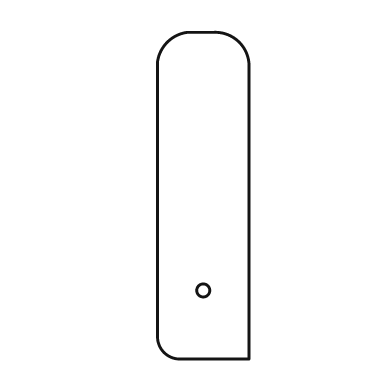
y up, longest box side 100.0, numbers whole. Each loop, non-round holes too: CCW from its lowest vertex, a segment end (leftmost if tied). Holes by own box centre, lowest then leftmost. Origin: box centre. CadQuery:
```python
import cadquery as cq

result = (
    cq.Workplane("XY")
    .moveTo(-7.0, -50.0)
    .lineTo(14.0, -50.0)
    .lineTo(14.0, 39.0)
    .threePointArc((11.0, 47.0), (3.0, 50.0))
    .lineTo(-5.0, 50.0)
    .threePointArc((-11.0, 47.0), (-14.0, 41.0))
    .lineTo(-14.0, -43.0)
    .threePointArc((-12.0, -48.0), (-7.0, -50.0))
    .close()
    .moveTo(0.0, -29.0)
    .circle(2.0)
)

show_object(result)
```